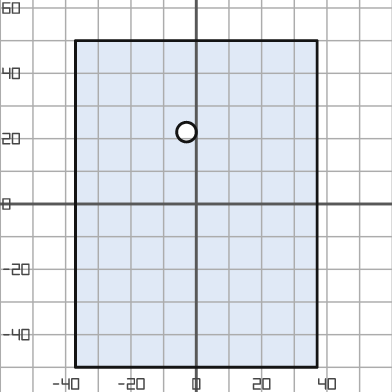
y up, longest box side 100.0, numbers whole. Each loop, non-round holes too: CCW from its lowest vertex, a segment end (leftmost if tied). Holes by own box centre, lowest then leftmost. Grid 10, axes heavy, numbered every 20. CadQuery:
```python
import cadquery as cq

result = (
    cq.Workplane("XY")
    .moveTo(-37.0, -50.0)
    .lineTo(37.0, -50.0)
    .lineTo(37.0, 50.0)
    .lineTo(-37.0, 50.0)
    .close()
    .moveTo(-3.0, 22.0)
    .circle(3.0)
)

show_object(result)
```